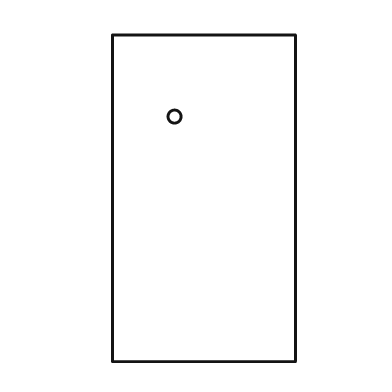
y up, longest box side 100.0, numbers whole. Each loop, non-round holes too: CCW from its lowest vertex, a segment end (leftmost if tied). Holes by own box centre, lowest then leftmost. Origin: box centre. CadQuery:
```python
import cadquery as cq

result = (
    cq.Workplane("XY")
    .moveTo(-28.0, -50.0)
    .lineTo(28.0, -50.0)
    .lineTo(28.0, 50.0)
    .lineTo(-28.0, 50.0)
    .close()
    .moveTo(-9.0, 25.0)
    .circle(2.0)
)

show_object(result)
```